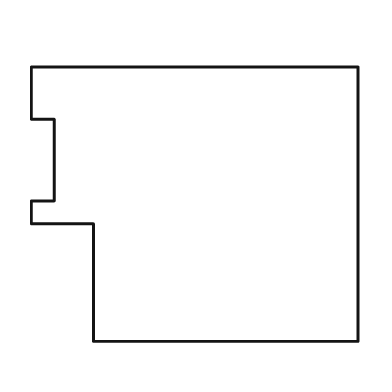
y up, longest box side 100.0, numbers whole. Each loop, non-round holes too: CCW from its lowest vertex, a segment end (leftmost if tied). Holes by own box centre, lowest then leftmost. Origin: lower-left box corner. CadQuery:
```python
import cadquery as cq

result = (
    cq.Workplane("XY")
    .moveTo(19.0, 0.0)
    .lineTo(100.0, 0.0)
    .lineTo(100.0, 84.0)
    .lineTo(0.0, 84.0)
    .lineTo(0.0, 68.0)
    .lineTo(7.0, 68.0)
    .lineTo(7.0, 43.0)
    .lineTo(0.0, 43.0)
    .lineTo(0.0, 36.0)
    .lineTo(19.0, 36.0)
    .close()
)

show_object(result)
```